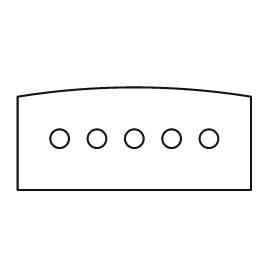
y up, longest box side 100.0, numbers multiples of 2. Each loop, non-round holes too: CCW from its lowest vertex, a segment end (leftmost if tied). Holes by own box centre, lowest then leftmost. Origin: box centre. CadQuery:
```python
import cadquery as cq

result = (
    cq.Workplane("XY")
    .moveTo(-50.0, -22.0)
    .lineTo(50.0, -22.0)
    .lineTo(50.0, 18.0)
    .threePointArc((0.0, 22.0), (-50.0, 18.0))
    .close()
    .moveTo(-32.0, 0.0)
    .circle(4.0)
    .moveTo(-16.0, 0.0)
    .circle(4.0)
    .moveTo(0.0, 0.0)
    .circle(4.0)
    .moveTo(16.0, 0.0)
    .circle(4.0)
    .moveTo(32.0, 0.0)
    .circle(4.0)
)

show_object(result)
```